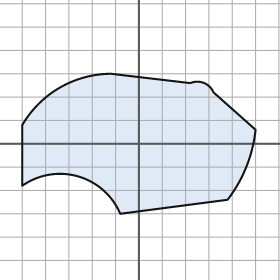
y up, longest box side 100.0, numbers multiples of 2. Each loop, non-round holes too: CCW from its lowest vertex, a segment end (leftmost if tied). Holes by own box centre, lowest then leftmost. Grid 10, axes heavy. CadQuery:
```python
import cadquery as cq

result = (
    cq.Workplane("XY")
    .moveTo(-8.0, -30.0)
    .lineTo(38.0, -24.0)
    .threePointArc((46.0, -10.0), (50.0, 6.0))
    .lineTo(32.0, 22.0)
    .threePointArc((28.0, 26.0), (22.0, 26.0))
    .lineTo(-12.0, 30.0)
    .threePointArc((-34.0, 24.0), (-50.0, 8.0))
    .lineTo(-50.0, -18.0)
    .threePointArc((-26.0, -14.0), (-8.0, -30.0))
    .close()
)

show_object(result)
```